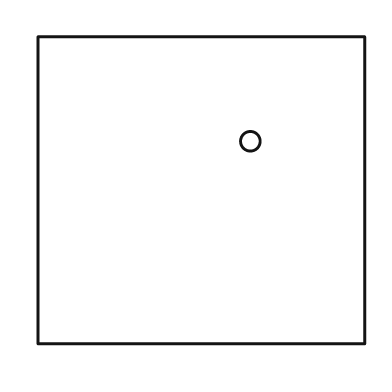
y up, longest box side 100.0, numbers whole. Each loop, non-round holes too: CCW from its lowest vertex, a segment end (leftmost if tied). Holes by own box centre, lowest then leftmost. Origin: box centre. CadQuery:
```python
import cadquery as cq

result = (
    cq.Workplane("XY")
    .moveTo(-50.0, -47.0)
    .lineTo(50.0, -47.0)
    .lineTo(50.0, 47.0)
    .lineTo(-50.0, 47.0)
    .close()
    .moveTo(15.0, 15.0)
    .circle(3.0)
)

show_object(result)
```